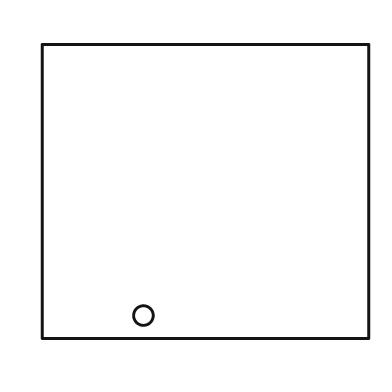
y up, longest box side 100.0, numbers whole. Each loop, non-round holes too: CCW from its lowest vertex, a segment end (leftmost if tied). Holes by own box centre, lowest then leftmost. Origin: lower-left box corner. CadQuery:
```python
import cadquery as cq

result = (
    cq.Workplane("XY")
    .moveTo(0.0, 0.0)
    .lineTo(100.0, 0.0)
    .lineTo(100.0, 90.0)
    .lineTo(0.0, 90.0)
    .close()
    .moveTo(31.0, 7.0)
    .circle(3.0)
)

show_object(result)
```